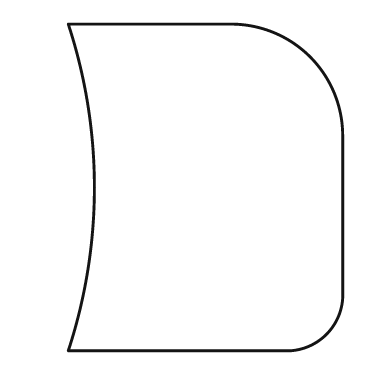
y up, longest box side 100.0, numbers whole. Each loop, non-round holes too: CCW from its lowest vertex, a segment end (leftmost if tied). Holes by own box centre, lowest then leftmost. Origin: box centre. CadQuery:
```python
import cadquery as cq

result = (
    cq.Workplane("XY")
    .moveTo(-42.0, -50.0)
    .lineTo(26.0, -50.0)
    .threePointArc((37.0, -45.0), (42.0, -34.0))
    .lineTo(42.0, 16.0)
    .threePointArc((32.0, 40.0), (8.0, 50.0))
    .lineTo(-42.0, 50.0)
    .threePointArc((-34.0, 0.0), (-42.0, -50.0))
    .close()
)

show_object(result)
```